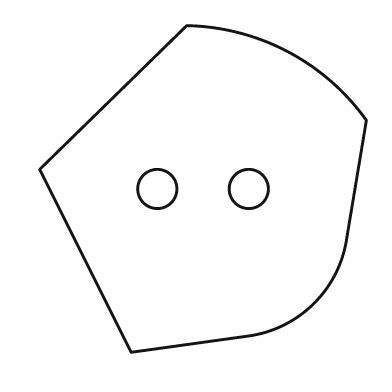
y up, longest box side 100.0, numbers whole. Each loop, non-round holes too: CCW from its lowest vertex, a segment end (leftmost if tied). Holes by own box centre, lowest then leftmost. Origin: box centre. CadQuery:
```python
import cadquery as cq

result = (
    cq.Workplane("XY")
    .moveTo(-22.0, -50.0)
    .lineTo(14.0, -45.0)
    .threePointArc((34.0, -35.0), (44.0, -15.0))
    .lineTo(50.0, 21.0)
    .threePointArc((26.0, 42.0), (-5.0, 50.0))
    .lineTo(-50.0, 6.0)
    .close()
    .moveTo(-14.0, 0.0)
    .circle(6.0)
    .moveTo(14.0, 0.0)
    .circle(6.0)
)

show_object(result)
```